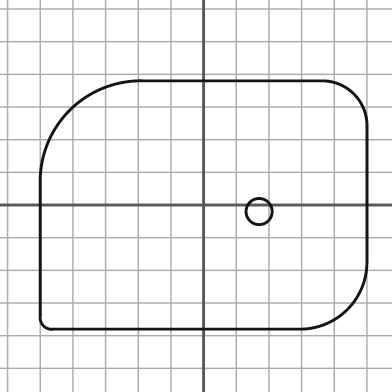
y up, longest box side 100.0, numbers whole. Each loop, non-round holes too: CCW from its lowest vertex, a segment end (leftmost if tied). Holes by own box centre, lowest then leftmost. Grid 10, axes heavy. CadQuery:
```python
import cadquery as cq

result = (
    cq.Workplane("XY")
    .moveTo(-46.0, -38.0)
    .lineTo(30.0, -38.0)
    .threePointArc((44.0, -32.0), (50.0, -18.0))
    .lineTo(50.0, 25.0)
    .threePointArc((46.0, 34.0), (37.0, 38.0))
    .lineTo(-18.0, 38.0)
    .threePointArc((-41.0, 29.0), (-50.0, 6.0))
    .lineTo(-50.0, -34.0)
    .threePointArc((-49.0, -37.0), (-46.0, -38.0))
    .close()
    .moveTo(17.0, -2.0)
    .circle(4.0)
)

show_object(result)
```